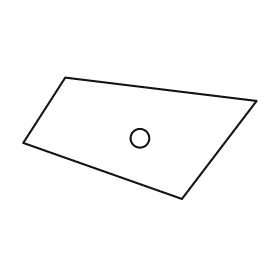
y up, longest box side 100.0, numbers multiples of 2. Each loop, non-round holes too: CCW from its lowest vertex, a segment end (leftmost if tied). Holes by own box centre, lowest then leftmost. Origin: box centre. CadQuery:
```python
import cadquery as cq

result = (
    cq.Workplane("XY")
    .moveTo(18.0, -26.0)
    .lineTo(50.0, 16.0)
    .lineTo(-32.0, 26.0)
    .lineTo(-50.0, -2.0)
    .close()
    .moveTo(0.0, 0.0)
    .circle(4.0)
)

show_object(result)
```